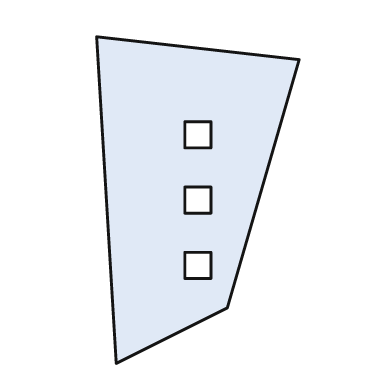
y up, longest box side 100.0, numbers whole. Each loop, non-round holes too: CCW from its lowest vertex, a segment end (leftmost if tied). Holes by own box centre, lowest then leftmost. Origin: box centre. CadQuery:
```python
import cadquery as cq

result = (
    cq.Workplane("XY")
    .moveTo(-25.0, -50.0)
    .lineTo(9.0, -33.0)
    .lineTo(31.0, 43.0)
    .lineTo(-31.0, 50.0)
    .close()
    .moveTo(-4.0, -24.0)
    .lineTo(4.0, -24.0)
    .lineTo(4.0, -16.0)
    .lineTo(-4.0, -16.0)
    .close()
    .moveTo(-4.0, -4.0)
    .lineTo(4.0, -4.0)
    .lineTo(4.0, 4.0)
    .lineTo(-4.0, 4.0)
    .close()
    .moveTo(-4.0, 16.0)
    .lineTo(4.0, 16.0)
    .lineTo(4.0, 24.0)
    .lineTo(-4.0, 24.0)
    .close()
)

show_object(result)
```